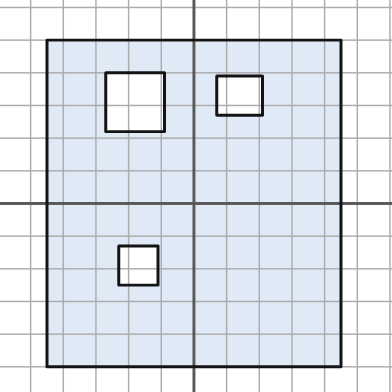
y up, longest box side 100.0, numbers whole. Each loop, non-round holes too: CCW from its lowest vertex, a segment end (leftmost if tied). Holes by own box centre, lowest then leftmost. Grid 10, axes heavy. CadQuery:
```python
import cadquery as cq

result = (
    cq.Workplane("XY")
    .moveTo(-45.0, -50.0)
    .lineTo(45.0, -50.0)
    .lineTo(45.0, 50.0)
    .lineTo(-45.0, 50.0)
    .close()
    .moveTo(-23.0, -25.0)
    .lineTo(-11.0, -25.0)
    .lineTo(-11.0, -13.0)
    .lineTo(-23.0, -13.0)
    .close()
    .moveTo(-27.0, 22.0)
    .lineTo(-9.0, 22.0)
    .lineTo(-9.0, 40.0)
    .lineTo(-27.0, 40.0)
    .close()
    .moveTo(7.0, 27.0)
    .lineTo(21.0, 27.0)
    .lineTo(21.0, 39.0)
    .lineTo(7.0, 39.0)
    .close()
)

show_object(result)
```